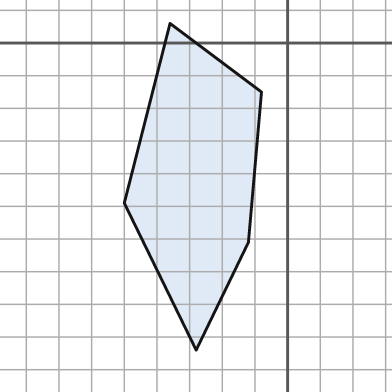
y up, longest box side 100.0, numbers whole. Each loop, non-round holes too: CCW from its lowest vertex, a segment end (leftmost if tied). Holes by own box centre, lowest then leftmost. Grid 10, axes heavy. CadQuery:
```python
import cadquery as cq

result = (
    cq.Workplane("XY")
    .moveTo(-28.0, -94.0)
    .lineTo(-12.0, -61.0)
    .lineTo(-8.0, -15.0)
    .lineTo(-36.0, 6.0)
    .lineTo(-50.0, -49.0)
    .close()
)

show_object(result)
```